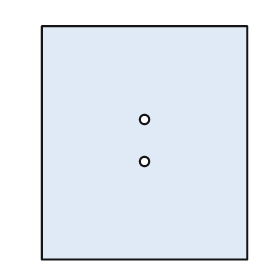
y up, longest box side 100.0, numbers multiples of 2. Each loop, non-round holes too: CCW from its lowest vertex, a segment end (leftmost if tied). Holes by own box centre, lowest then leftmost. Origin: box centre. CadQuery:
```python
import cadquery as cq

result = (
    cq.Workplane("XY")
    .moveTo(-44.0, -50.0)
    .lineTo(44.0, -50.0)
    .lineTo(44.0, 50.0)
    .lineTo(-44.0, 50.0)
    .close()
    .moveTo(0.0, -8.0)
    .circle(2.0)
    .moveTo(0.0, 10.0)
    .circle(2.0)
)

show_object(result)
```